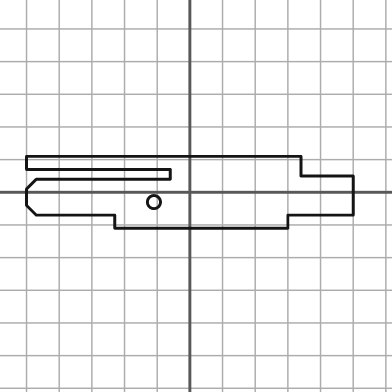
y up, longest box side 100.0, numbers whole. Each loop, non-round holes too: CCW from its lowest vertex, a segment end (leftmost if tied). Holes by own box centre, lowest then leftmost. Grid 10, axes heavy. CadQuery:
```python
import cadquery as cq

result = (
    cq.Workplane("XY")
    .moveTo(-23.0, -11.0)
    .lineTo(30.0, -11.0)
    .lineTo(30.0, -7.0)
    .lineTo(50.0, -7.0)
    .lineTo(50.0, 5.0)
    .lineTo(34.0, 5.0)
    .lineTo(34.0, 11.0)
    .lineTo(-50.0, 11.0)
    .lineTo(-50.0, 7.0)
    .lineTo(-6.0, 7.0)
    .lineTo(-6.0, 4.0)
    .lineTo(-47.0, 4.0)
    .lineTo(-50.0, 1.0)
    .lineTo(-50.0, -4.0)
    .lineTo(-47.0, -7.0)
    .lineTo(-23.0, -7.0)
    .close()
    .moveTo(-11.0, -3.0)
    .circle(2.0)
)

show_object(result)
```